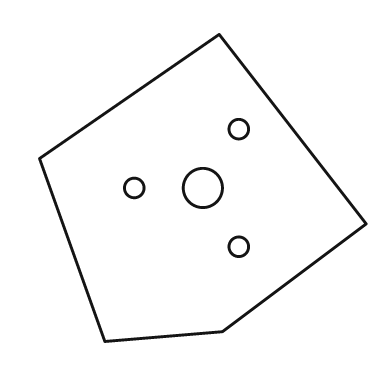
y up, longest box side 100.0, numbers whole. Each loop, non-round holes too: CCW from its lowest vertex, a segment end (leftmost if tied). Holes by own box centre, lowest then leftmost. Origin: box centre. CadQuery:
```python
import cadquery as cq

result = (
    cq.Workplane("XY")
    .moveTo(-30.0, -47.0)
    .lineTo(6.0, -44.0)
    .lineTo(50.0, -11.0)
    .lineTo(5.0, 47.0)
    .lineTo(-50.0, 9.0)
    .close()
    .moveTo(11.0, -18.0)
    .circle(3.0)
    .moveTo(-21.0, 0.0)
    .circle(3.0)
    .moveTo(0.0, 0.0)
    .circle(6.0)
    .moveTo(11.0, 18.0)
    .circle(3.0)
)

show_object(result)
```